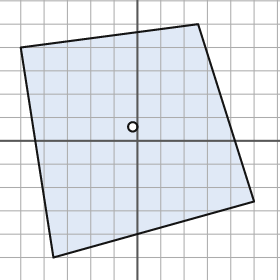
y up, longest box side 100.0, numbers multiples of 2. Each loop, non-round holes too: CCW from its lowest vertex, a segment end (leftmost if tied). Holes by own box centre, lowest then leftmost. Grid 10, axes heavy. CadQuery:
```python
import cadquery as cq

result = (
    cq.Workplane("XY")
    .moveTo(-36.0, -50.0)
    .lineTo(50.0, -26.0)
    .lineTo(26.0, 50.0)
    .lineTo(-50.0, 40.0)
    .close()
    .moveTo(-2.0, 6.0)
    .circle(2.0)
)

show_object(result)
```